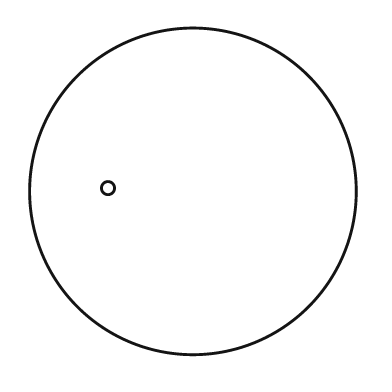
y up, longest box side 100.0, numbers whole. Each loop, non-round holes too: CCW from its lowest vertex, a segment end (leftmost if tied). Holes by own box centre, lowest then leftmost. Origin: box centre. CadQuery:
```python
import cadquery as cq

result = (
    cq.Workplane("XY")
    .moveTo(0.0, 0.0)
    .circle(50.0)
    .moveTo(-26.0, 1.0)
    .circle(2.0)
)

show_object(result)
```